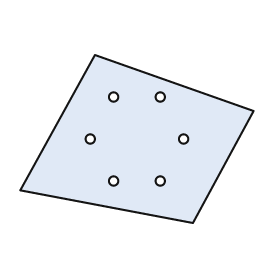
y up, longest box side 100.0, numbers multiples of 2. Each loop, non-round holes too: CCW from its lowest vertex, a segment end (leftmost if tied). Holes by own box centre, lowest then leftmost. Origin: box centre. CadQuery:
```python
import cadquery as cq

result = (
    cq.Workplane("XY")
    .moveTo(24.0, -36.0)
    .lineTo(50.0, 12.0)
    .lineTo(-18.0, 36.0)
    .lineTo(-50.0, -22.0)
    .close()
    .moveTo(-10.0, -18.0)
    .circle(2.0)
    .moveTo(10.0, -18.0)
    .circle(2.0)
    .moveTo(-20.0, 0.0)
    .circle(2.0)
    .moveTo(20.0, 0.0)
    .circle(2.0)
    .moveTo(-10.0, 18.0)
    .circle(2.0)
    .moveTo(10.0, 18.0)
    .circle(2.0)
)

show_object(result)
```